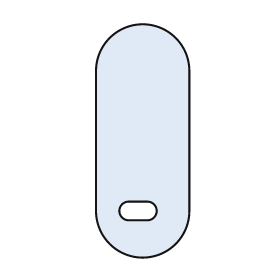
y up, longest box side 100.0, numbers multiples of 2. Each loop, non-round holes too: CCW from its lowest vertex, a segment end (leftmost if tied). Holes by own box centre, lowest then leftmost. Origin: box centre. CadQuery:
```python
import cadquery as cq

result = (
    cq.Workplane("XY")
    .moveTo(-20.0, -30.0)
    .threePointArc((0.0, -50.0), (20.0, -30.0))
    .lineTo(20.0, 30.0)
    .threePointArc((0.0, 50.0), (-20.0, 30.0))
    .close()
    .moveTo(-6.0, -34.0)
    .lineTo(2.0, -34.0)
    .threePointArc((6.0, -30.0), (2.0, -26.0))
    .lineTo(-6.0, -26.0)
    .threePointArc((-10.0, -30.0), (-6.0, -34.0))
    .close()
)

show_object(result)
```